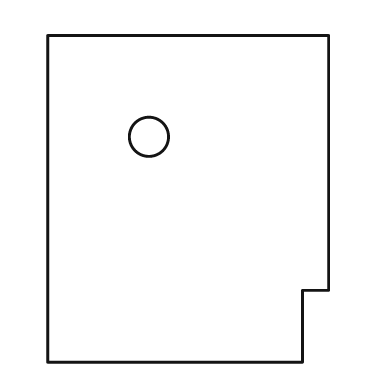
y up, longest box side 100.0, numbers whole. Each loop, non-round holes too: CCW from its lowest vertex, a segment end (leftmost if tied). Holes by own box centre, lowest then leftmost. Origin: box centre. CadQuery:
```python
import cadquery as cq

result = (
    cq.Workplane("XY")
    .moveTo(-43.0, -50.0)
    .lineTo(35.0, -50.0)
    .lineTo(35.0, -28.0)
    .lineTo(43.0, -28.0)
    .lineTo(43.0, 50.0)
    .lineTo(-43.0, 50.0)
    .close()
    .moveTo(-12.0, 19.0)
    .circle(6.0)
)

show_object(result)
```